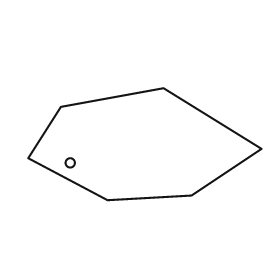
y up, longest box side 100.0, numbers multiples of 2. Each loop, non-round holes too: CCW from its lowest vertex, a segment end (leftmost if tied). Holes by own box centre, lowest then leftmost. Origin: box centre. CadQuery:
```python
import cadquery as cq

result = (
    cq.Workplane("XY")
    .moveTo(-16.0, -24.0)
    .lineTo(20.0, -22.0)
    .lineTo(50.0, -2.0)
    .lineTo(8.0, 24.0)
    .lineTo(-36.0, 16.0)
    .lineTo(-50.0, -6.0)
    .close()
    .moveTo(-32.0, -8.0)
    .circle(2.0)
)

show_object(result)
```